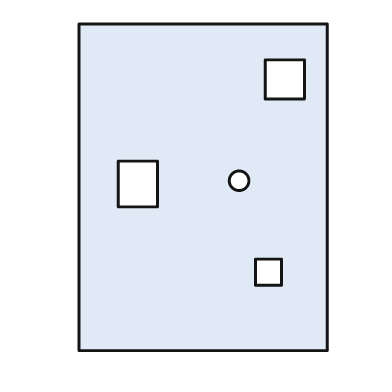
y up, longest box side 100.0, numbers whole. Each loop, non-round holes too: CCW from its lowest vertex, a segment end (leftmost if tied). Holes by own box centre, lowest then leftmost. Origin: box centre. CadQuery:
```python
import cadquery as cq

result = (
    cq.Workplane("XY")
    .moveTo(-38.0, -50.0)
    .lineTo(38.0, -50.0)
    .lineTo(38.0, 50.0)
    .lineTo(-38.0, 50.0)
    .close()
    .moveTo(16.0, -30.0)
    .lineTo(24.0, -30.0)
    .lineTo(24.0, -22.0)
    .lineTo(16.0, -22.0)
    .close()
    .moveTo(-26.0, -6.0)
    .lineTo(-14.0, -6.0)
    .lineTo(-14.0, 8.0)
    .lineTo(-26.0, 8.0)
    .close()
    .moveTo(11.0, 2.0)
    .circle(3.0)
    .moveTo(19.0, 27.0)
    .lineTo(31.0, 27.0)
    .lineTo(31.0, 39.0)
    .lineTo(19.0, 39.0)
    .close()
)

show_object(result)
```